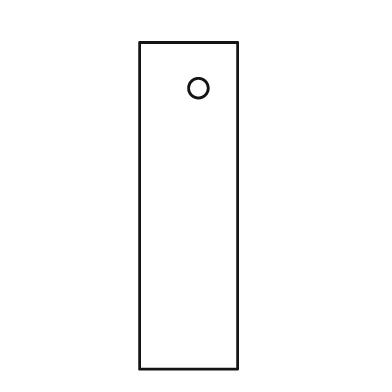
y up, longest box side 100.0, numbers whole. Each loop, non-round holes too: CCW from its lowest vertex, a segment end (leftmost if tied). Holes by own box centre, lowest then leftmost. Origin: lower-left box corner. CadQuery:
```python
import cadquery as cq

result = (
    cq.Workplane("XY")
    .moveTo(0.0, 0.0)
    .lineTo(30.0, 0.0)
    .lineTo(30.0, 100.0)
    .lineTo(0.0, 100.0)
    .close()
    .moveTo(18.0, 86.0)
    .circle(3.0)
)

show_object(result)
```